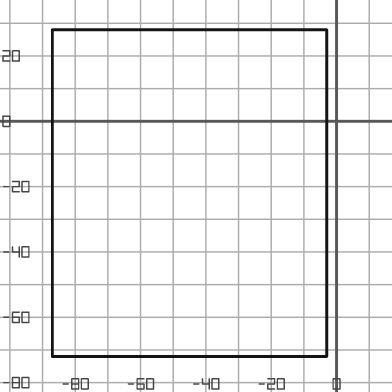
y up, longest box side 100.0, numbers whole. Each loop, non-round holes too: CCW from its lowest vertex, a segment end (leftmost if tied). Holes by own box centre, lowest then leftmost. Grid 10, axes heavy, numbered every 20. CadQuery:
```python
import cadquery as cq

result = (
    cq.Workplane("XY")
    .moveTo(-87.0, -72.0)
    .lineTo(-3.0, -72.0)
    .lineTo(-3.0, 28.0)
    .lineTo(-87.0, 28.0)
    .close()
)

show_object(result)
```